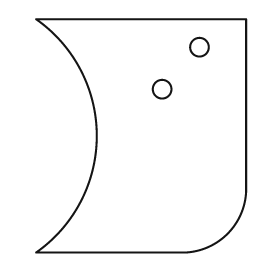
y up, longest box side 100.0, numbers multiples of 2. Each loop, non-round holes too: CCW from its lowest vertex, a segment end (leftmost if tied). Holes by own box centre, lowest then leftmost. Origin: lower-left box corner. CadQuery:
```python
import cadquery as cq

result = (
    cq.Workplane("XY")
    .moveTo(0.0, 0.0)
    .lineTo(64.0, 0.0)
    .threePointArc((82.0, 8.0), (90.0, 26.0))
    .lineTo(90.0, 100.0)
    .lineTo(0.0, 100.0)
    .threePointArc((26.0, 50.0), (0.0, 0.0))
    .close()
    .moveTo(54.0, 70.0)
    .circle(4.0)
    .moveTo(70.0, 88.0)
    .circle(4.0)
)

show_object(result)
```